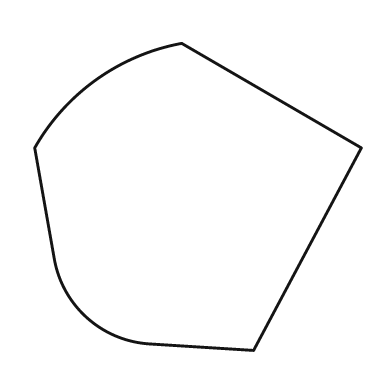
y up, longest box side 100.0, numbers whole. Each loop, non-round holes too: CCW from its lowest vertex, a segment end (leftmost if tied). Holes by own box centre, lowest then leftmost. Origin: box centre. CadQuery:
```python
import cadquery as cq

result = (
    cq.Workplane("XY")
    .moveTo(17.0, -47.0)
    .lineTo(50.0, 15.0)
    .lineTo(-5.0, 47.0)
    .threePointArc((-31.0, 36.0), (-50.0, 15.0))
    .lineTo(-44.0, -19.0)
    .threePointArc((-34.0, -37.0), (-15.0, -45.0))
    .close()
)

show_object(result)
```